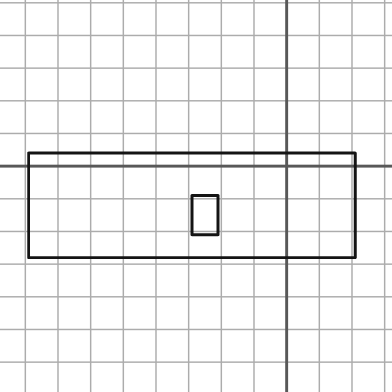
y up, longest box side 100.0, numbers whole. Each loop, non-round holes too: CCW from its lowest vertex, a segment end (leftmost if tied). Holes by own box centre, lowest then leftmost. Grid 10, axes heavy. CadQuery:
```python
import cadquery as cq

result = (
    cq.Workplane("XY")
    .moveTo(-79.0, -28.0)
    .lineTo(21.0, -28.0)
    .lineTo(21.0, 4.0)
    .lineTo(-79.0, 4.0)
    .close()
    .moveTo(-29.0, -21.0)
    .lineTo(-21.0, -21.0)
    .lineTo(-21.0, -9.0)
    .lineTo(-29.0, -9.0)
    .close()
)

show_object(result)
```